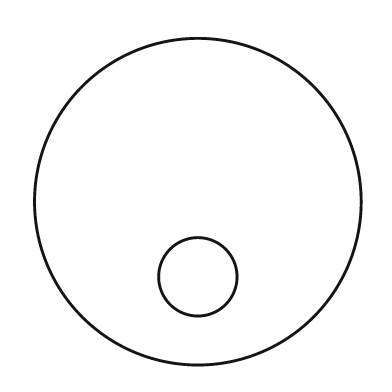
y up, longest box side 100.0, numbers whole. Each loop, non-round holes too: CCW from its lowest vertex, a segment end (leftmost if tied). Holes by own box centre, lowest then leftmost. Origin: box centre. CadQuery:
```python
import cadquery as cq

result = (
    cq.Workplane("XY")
    .moveTo(0.0, 0.0)
    .circle(50.0)
    .moveTo(0.0, -23.0)
    .circle(12.0)
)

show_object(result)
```